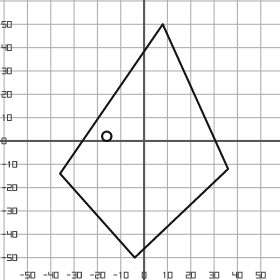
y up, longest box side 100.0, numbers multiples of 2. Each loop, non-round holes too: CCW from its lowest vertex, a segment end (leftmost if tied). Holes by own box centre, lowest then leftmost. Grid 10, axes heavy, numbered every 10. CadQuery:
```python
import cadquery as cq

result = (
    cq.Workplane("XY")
    .moveTo(-4.0, -50.0)
    .lineTo(36.0, -12.0)
    .lineTo(8.0, 50.0)
    .lineTo(-36.0, -14.0)
    .close()
    .moveTo(-16.0, 2.0)
    .circle(2.0)
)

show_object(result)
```